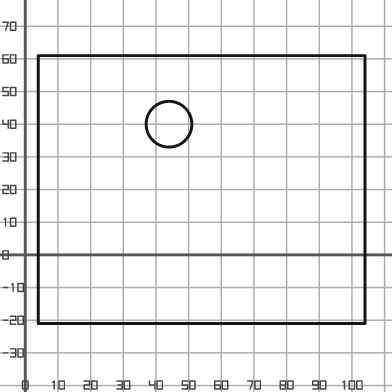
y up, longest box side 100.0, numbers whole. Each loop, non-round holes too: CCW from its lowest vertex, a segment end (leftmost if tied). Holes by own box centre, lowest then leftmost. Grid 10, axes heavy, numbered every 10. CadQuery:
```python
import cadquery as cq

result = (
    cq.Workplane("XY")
    .moveTo(4.0, -21.0)
    .lineTo(104.0, -21.0)
    .lineTo(104.0, 61.0)
    .lineTo(4.0, 61.0)
    .close()
    .moveTo(44.0, 40.0)
    .circle(7.0)
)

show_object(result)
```